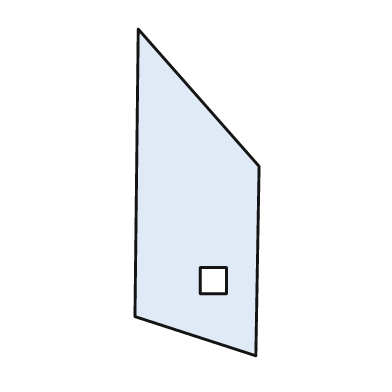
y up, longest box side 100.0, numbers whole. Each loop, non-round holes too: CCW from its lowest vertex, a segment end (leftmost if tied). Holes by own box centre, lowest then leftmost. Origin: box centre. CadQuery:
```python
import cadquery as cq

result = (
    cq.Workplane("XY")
    .moveTo(18.0, -50.0)
    .lineTo(19.0, 8.0)
    .lineTo(-18.0, 50.0)
    .lineTo(-19.0, -38.0)
    .close()
    .moveTo(1.0, -31.0)
    .lineTo(9.0, -31.0)
    .lineTo(9.0, -23.0)
    .lineTo(1.0, -23.0)
    .close()
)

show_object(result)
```